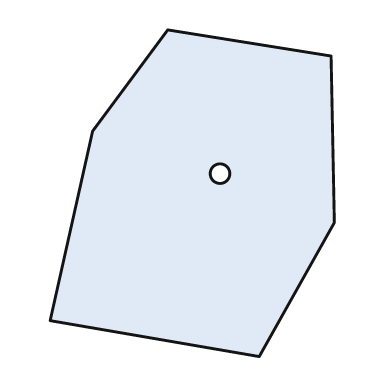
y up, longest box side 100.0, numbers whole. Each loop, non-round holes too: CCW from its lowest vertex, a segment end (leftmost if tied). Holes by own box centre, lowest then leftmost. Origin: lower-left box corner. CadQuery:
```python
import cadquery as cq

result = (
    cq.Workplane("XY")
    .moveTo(64.0, 0.0)
    .lineTo(87.0, 41.0)
    .lineTo(86.0, 92.0)
    .lineTo(36.0, 100.0)
    .lineTo(13.0, 69.0)
    .lineTo(0.0, 11.0)
    .close()
    .moveTo(52.0, 56.0)
    .circle(3.0)
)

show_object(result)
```